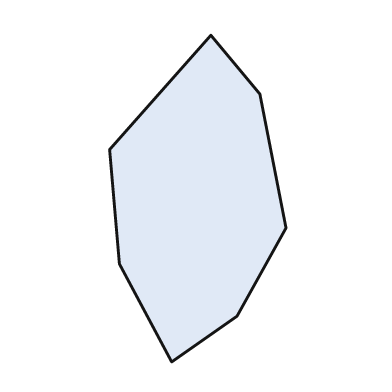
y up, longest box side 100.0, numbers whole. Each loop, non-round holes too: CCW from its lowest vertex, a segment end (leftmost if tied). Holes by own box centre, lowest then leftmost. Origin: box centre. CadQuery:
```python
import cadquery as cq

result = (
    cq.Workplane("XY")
    .moveTo(-8.0, -50.0)
    .lineTo(12.0, -36.0)
    .lineTo(27.0, -9.0)
    .lineTo(19.0, 32.0)
    .lineTo(4.0, 50.0)
    .lineTo(-27.0, 15.0)
    .lineTo(-24.0, -20.0)
    .close()
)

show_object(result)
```